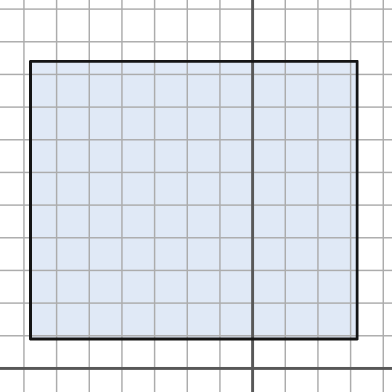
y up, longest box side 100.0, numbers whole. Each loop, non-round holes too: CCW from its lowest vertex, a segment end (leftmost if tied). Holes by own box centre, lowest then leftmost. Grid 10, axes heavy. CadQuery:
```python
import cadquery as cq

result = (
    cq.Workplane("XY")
    .moveTo(-68.0, 9.0)
    .lineTo(32.0, 9.0)
    .lineTo(32.0, 94.0)
    .lineTo(-68.0, 94.0)
    .close()
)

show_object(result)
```